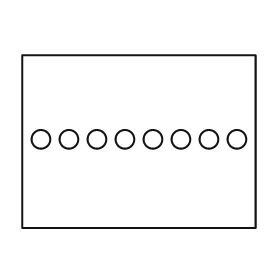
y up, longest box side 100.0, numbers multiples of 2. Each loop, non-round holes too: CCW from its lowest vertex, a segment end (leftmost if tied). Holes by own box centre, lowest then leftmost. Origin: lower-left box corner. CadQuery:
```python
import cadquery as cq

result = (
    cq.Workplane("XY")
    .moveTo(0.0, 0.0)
    .lineTo(100.0, 0.0)
    .lineTo(100.0, 74.0)
    .lineTo(0.0, 74.0)
    .close()
    .moveTo(8.0, 38.0)
    .circle(4.0)
    .moveTo(20.0, 38.0)
    .circle(4.0)
    .moveTo(32.0, 38.0)
    .circle(4.0)
    .moveTo(44.0, 38.0)
    .circle(4.0)
    .moveTo(56.0, 38.0)
    .circle(4.0)
    .moveTo(68.0, 38.0)
    .circle(4.0)
    .moveTo(80.0, 38.0)
    .circle(4.0)
    .moveTo(92.0, 38.0)
    .circle(4.0)
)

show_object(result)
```